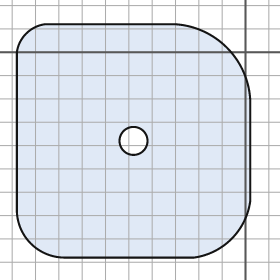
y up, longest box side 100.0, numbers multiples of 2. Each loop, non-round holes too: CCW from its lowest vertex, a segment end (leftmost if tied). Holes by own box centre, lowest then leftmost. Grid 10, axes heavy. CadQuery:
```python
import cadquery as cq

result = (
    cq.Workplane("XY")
    .moveTo(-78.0, -88.0)
    .lineTo(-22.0, -88.0)
    .threePointArc((-6.0, -80.0), (2.0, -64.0))
    .lineTo(2.0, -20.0)
    .threePointArc((-8.0, 2.0), (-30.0, 12.0))
    .lineTo(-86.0, 12.0)
    .threePointArc((-94.0, 8.0), (-98.0, 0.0))
    .lineTo(-98.0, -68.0)
    .threePointArc((-92.0, -82.0), (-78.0, -88.0))
    .close()
    .moveTo(-48.0, -38.0)
    .circle(6.0)
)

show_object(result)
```